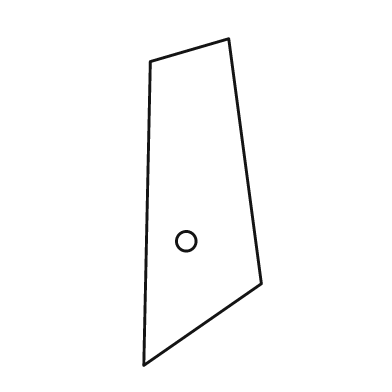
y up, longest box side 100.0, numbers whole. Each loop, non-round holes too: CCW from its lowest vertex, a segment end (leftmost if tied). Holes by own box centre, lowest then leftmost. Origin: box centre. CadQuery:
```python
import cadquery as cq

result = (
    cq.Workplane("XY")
    .moveTo(-18.0, -50.0)
    .lineTo(18.0, -25.0)
    .lineTo(8.0, 50.0)
    .lineTo(-16.0, 43.0)
    .close()
    .moveTo(-5.0, -12.0)
    .circle(3.0)
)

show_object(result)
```